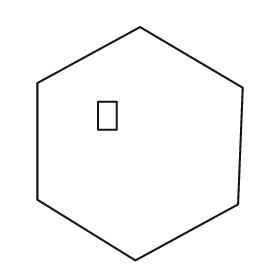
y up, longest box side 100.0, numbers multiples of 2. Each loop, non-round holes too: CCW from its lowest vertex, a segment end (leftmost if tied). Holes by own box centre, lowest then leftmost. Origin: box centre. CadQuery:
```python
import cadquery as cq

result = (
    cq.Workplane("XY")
    .moveTo(-2.0, -50.0)
    .lineTo(42.0, -26.0)
    .lineTo(44.0, 24.0)
    .lineTo(0.0, 50.0)
    .lineTo(-44.0, 26.0)
    .lineTo(-44.0, -24.0)
    .close()
    .moveTo(-18.0, 6.0)
    .lineTo(-10.0, 6.0)
    .lineTo(-10.0, 18.0)
    .lineTo(-18.0, 18.0)
    .close()
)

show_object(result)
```